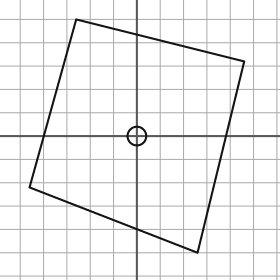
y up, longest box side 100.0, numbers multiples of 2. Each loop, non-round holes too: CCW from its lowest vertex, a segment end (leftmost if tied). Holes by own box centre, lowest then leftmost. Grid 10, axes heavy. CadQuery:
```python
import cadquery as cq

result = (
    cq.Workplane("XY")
    .moveTo(26.0, -50.0)
    .lineTo(46.0, 32.0)
    .lineTo(-26.0, 50.0)
    .lineTo(-46.0, -22.0)
    .close()
    .moveTo(0.0, 0.0)
    .circle(4.0)
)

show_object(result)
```